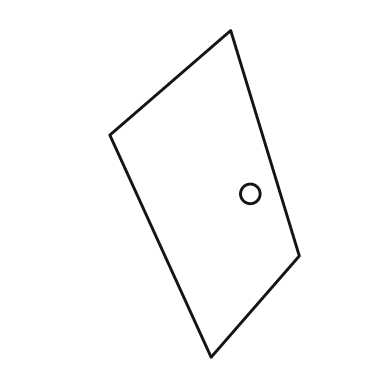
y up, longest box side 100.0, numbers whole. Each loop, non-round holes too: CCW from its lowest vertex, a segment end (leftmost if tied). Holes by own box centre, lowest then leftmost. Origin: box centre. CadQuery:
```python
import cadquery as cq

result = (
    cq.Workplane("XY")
    .moveTo(2.0, -50.0)
    .lineTo(29.0, -19.0)
    .lineTo(8.0, 50.0)
    .lineTo(-29.0, 18.0)
    .close()
    .moveTo(14.0, 0.0)
    .circle(3.0)
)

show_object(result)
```